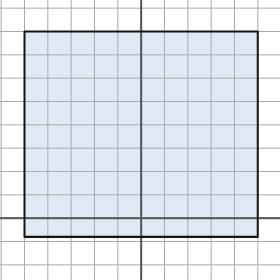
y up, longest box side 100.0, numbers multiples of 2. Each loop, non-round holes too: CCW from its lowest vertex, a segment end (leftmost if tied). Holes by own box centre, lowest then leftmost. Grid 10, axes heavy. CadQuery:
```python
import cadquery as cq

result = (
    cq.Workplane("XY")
    .moveTo(-50.0, -8.0)
    .lineTo(50.0, -8.0)
    .lineTo(50.0, 80.0)
    .lineTo(-50.0, 80.0)
    .close()
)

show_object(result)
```